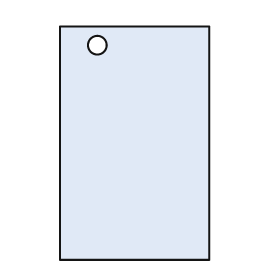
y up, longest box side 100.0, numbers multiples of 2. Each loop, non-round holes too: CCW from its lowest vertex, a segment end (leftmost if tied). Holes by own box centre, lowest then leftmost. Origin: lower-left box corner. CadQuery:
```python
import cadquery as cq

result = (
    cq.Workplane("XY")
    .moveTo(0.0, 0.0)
    .lineTo(64.0, 0.0)
    .lineTo(64.0, 100.0)
    .lineTo(0.0, 100.0)
    .close()
    .moveTo(16.0, 92.0)
    .circle(4.0)
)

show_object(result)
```